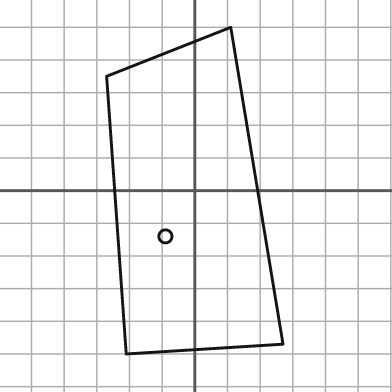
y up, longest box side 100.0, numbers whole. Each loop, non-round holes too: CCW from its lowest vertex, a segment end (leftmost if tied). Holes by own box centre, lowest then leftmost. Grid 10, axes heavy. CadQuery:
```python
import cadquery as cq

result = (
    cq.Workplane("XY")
    .moveTo(-21.0, -50.0)
    .lineTo(27.0, -47.0)
    .lineTo(11.0, 50.0)
    .lineTo(-27.0, 35.0)
    .close()
    .moveTo(-9.0, -14.0)
    .circle(2.0)
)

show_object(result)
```